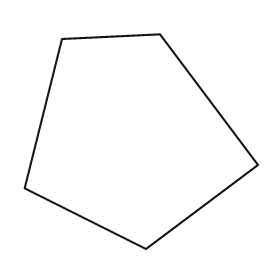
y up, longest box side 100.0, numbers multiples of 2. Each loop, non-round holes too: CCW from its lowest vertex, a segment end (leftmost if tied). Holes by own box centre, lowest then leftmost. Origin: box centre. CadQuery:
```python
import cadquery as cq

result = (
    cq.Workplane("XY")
    .moveTo(2.0, -46.0)
    .lineTo(50.0, -10.0)
    .lineTo(8.0, 46.0)
    .lineTo(-34.0, 44.0)
    .lineTo(-50.0, -20.0)
    .close()
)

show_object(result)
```